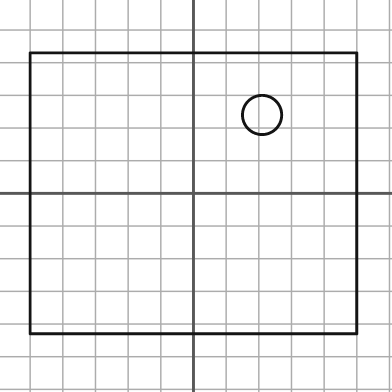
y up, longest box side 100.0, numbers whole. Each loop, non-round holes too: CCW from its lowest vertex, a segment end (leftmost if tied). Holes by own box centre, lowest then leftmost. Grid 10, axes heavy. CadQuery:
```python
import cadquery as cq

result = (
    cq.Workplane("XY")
    .moveTo(-50.0, -43.0)
    .lineTo(50.0, -43.0)
    .lineTo(50.0, 43.0)
    .lineTo(-50.0, 43.0)
    .close()
    .moveTo(21.0, 24.0)
    .circle(6.0)
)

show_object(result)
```